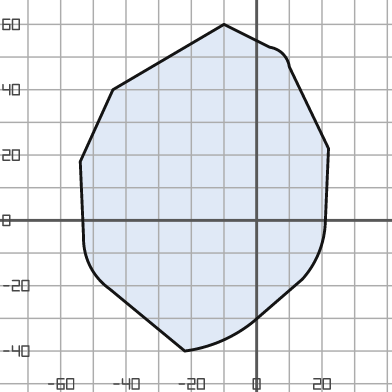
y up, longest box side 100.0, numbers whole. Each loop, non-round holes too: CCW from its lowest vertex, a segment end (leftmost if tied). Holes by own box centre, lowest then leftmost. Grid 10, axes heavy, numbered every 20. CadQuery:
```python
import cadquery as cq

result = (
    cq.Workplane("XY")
    .moveTo(-22.0, -40.0)
    .threePointArc((-11.0, -37.0), (-1.0, -31.0))
    .lineTo(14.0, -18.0)
    .threePointArc((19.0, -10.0), (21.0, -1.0))
    .lineTo(22.0, 22.0)
    .lineTo(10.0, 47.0)
    .threePointArc((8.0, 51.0), (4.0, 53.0))
    .lineTo(-10.0, 60.0)
    .lineTo(-44.0, 40.0)
    .lineTo(-54.0, 18.0)
    .lineTo(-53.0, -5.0)
    .threePointArc((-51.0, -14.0), (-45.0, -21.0))
    .close()
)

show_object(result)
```